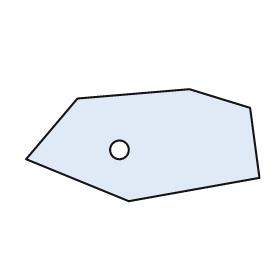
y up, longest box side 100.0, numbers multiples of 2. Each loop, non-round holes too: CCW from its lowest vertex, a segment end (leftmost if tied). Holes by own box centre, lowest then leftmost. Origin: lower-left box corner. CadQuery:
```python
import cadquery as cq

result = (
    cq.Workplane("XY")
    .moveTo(44.0, 0.0)
    .lineTo(100.0, 10.0)
    .lineTo(96.0, 40.0)
    .lineTo(70.0, 48.0)
    .lineTo(22.0, 44.0)
    .lineTo(0.0, 18.0)
    .close()
    .moveTo(40.0, 22.0)
    .circle(4.0)
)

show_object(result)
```